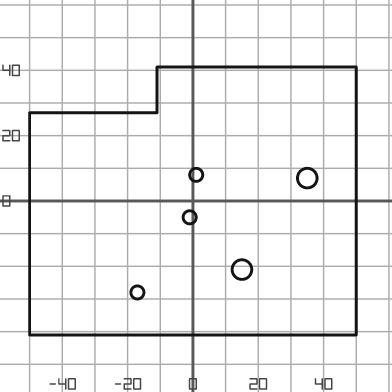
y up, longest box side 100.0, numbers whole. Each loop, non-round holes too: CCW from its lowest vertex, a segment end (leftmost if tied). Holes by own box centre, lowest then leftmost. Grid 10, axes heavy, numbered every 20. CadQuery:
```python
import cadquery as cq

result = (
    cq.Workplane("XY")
    .moveTo(-50.0, -41.0)
    .lineTo(50.0, -41.0)
    .lineTo(50.0, 41.0)
    .lineTo(-11.0, 41.0)
    .lineTo(-11.0, 27.0)
    .lineTo(-50.0, 27.0)
    .close()
    .moveTo(-17.0, -28.0)
    .circle(2.0)
    .moveTo(15.0, -21.0)
    .circle(3.0)
    .moveTo(-1.0, -5.0)
    .circle(2.0)
    .moveTo(35.0, 7.0)
    .circle(3.0)
    .moveTo(1.0, 8.0)
    .circle(2.0)
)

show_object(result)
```